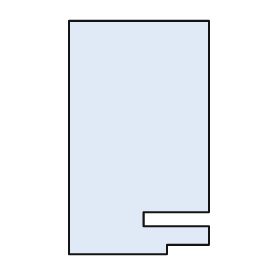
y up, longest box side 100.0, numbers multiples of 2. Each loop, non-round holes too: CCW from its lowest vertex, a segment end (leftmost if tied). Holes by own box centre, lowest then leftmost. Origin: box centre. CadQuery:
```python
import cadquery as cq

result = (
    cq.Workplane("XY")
    .moveTo(-30.0, -50.0)
    .lineTo(12.0, -50.0)
    .lineTo(12.0, -46.0)
    .lineTo(30.0, -46.0)
    .lineTo(30.0, -38.0)
    .lineTo(2.0, -38.0)
    .lineTo(2.0, -32.0)
    .lineTo(30.0, -32.0)
    .lineTo(30.0, 50.0)
    .lineTo(-30.0, 50.0)
    .close()
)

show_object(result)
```